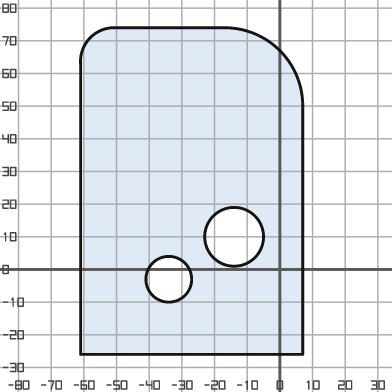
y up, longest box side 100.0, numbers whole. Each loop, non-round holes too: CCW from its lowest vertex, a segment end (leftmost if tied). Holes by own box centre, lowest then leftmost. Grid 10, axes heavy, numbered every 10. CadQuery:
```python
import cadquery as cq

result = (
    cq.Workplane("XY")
    .moveTo(-61.0, -26.0)
    .lineTo(7.0, -26.0)
    .lineTo(7.0, 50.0)
    .threePointArc((0.0, 67.0), (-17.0, 74.0))
    .lineTo(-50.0, 74.0)
    .threePointArc((-58.0, 71.0), (-61.0, 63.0))
    .close()
    .moveTo(-34.0, -3.0)
    .circle(7.0)
    .moveTo(-14.0, 10.0)
    .circle(9.0)
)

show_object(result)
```